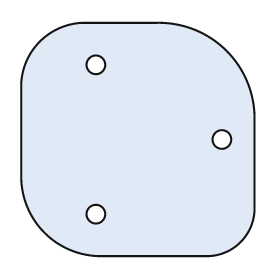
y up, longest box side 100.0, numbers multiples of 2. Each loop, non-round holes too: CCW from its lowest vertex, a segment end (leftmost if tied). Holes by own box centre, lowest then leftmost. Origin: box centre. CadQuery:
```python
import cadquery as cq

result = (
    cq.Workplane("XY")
    .moveTo(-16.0, -50.0)
    .lineTo(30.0, -50.0)
    .threePointArc((44.0, -44.0), (50.0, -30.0))
    .lineTo(50.0, 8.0)
    .threePointArc((38.0, 38.0), (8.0, 50.0))
    .lineTo(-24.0, 50.0)
    .threePointArc((-42.0, 42.0), (-50.0, 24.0))
    .lineTo(-50.0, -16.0)
    .threePointArc((-40.0, -40.0), (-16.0, -50.0))
    .close()
    .moveTo(-18.0, -32.0)
    .circle(4.0)
    .moveTo(36.0, 0.0)
    .circle(4.0)
    .moveTo(-18.0, 32.0)
    .circle(4.0)
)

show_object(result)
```